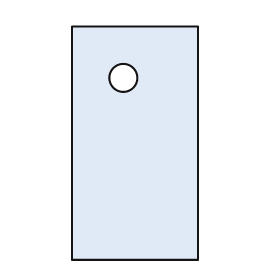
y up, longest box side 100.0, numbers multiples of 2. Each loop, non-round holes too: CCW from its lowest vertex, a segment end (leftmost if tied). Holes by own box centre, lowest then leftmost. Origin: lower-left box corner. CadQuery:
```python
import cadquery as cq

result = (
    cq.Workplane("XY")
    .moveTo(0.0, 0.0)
    .lineTo(54.0, 0.0)
    .lineTo(54.0, 100.0)
    .lineTo(0.0, 100.0)
    .close()
    .moveTo(22.0, 78.0)
    .circle(6.0)
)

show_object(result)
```